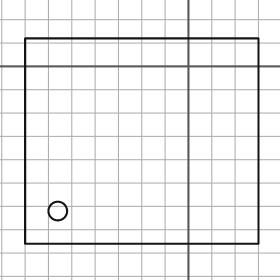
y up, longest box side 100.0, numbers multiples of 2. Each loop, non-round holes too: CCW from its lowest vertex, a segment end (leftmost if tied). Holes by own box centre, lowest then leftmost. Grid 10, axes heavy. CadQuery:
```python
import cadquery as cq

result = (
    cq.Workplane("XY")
    .moveTo(-70.0, -76.0)
    .lineTo(30.0, -76.0)
    .lineTo(30.0, 12.0)
    .lineTo(-70.0, 12.0)
    .close()
    .moveTo(-56.0, -62.0)
    .circle(4.0)
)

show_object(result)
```